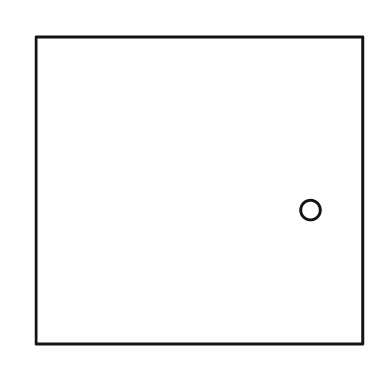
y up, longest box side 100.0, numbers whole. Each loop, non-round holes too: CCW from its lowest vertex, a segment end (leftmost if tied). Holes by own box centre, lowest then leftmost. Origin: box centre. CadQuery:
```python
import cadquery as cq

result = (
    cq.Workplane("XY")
    .moveTo(-50.0, -47.0)
    .lineTo(50.0, -47.0)
    .lineTo(50.0, 47.0)
    .lineTo(-50.0, 47.0)
    .close()
    .moveTo(34.0, -6.0)
    .circle(3.0)
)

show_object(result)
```